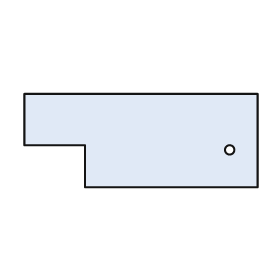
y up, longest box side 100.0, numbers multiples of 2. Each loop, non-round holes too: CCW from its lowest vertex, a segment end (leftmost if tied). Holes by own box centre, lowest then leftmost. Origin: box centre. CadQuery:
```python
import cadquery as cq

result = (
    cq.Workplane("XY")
    .moveTo(-24.0, -20.0)
    .lineTo(50.0, -20.0)
    .lineTo(50.0, 20.0)
    .lineTo(-50.0, 20.0)
    .lineTo(-50.0, -2.0)
    .lineTo(-24.0, -2.0)
    .close()
    .moveTo(38.0, -4.0)
    .circle(2.0)
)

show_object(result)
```